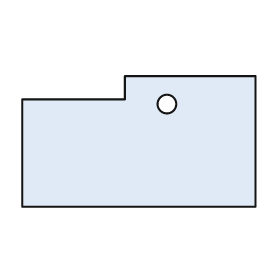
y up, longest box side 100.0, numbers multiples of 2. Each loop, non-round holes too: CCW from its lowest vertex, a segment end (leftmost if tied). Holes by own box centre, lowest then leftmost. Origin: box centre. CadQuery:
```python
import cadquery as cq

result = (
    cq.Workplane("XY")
    .moveTo(-50.0, -28.0)
    .lineTo(50.0, -28.0)
    .lineTo(50.0, 28.0)
    .lineTo(-6.0, 28.0)
    .lineTo(-6.0, 18.0)
    .lineTo(-50.0, 18.0)
    .close()
    .moveTo(12.0, 16.0)
    .circle(4.0)
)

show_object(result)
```